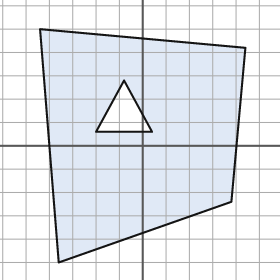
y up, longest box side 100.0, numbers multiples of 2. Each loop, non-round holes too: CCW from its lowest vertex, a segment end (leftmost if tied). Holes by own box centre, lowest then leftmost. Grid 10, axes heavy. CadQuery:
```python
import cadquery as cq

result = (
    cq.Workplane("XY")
    .moveTo(-36.0, -50.0)
    .lineTo(38.0, -24.0)
    .lineTo(44.0, 42.0)
    .lineTo(-44.0, 50.0)
    .close()
    .moveTo(-20.0, 6.0)
    .lineTo(4.0, 6.0)
    .lineTo(-8.0, 28.0)
    .close()
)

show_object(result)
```